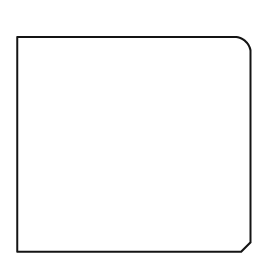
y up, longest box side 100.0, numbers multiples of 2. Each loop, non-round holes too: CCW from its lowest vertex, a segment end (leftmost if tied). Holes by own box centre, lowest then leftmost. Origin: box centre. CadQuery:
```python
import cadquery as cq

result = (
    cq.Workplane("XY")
    .moveTo(-50.0, -46.0)
    .lineTo(46.0, -46.0)
    .lineTo(50.0, -42.0)
    .lineTo(50.0, 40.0)
    .threePointArc((48.0, 44.0), (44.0, 46.0))
    .lineTo(-50.0, 46.0)
    .close()
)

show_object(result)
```